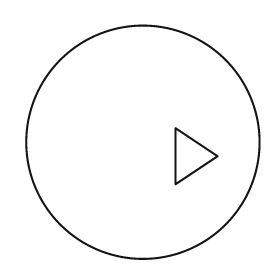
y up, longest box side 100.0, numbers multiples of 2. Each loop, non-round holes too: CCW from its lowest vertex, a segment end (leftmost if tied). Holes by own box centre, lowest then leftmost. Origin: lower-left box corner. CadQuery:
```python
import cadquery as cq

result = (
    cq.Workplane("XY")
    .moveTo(50.0, 50.0)
    .circle(50.0)
    .moveTo(64.0, 32.0)
    .lineTo(82.0, 44.0)
    .lineTo(64.0, 56.0)
    .close()
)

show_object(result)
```